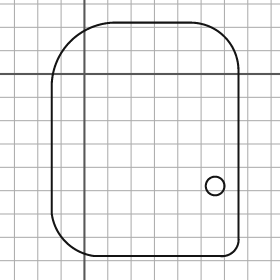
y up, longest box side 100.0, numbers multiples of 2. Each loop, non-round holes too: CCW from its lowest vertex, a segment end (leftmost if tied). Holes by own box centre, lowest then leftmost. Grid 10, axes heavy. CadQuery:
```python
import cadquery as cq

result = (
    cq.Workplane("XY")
    .moveTo(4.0, -78.0)
    .lineTo(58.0, -78.0)
    .threePointArc((64.0, -76.0), (66.0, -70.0))
    .lineTo(66.0, 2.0)
    .threePointArc((60.0, 16.0), (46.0, 22.0))
    .lineTo(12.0, 22.0)
    .threePointArc((-6.0, 14.0), (-14.0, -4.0))
    .lineTo(-14.0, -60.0)
    .threePointArc((-8.0, -72.0), (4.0, -78.0))
    .close()
    .moveTo(56.0, -48.0)
    .circle(4.0)
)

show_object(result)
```